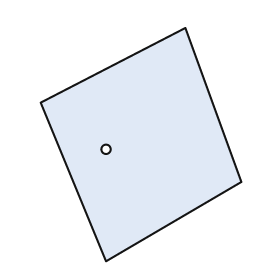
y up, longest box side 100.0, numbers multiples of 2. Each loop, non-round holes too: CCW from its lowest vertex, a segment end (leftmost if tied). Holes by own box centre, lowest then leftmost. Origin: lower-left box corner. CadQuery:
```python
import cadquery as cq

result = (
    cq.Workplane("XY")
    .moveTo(28.0, 0.0)
    .lineTo(86.0, 34.0)
    .lineTo(62.0, 100.0)
    .lineTo(0.0, 68.0)
    .close()
    .moveTo(28.0, 48.0)
    .circle(2.0)
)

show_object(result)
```